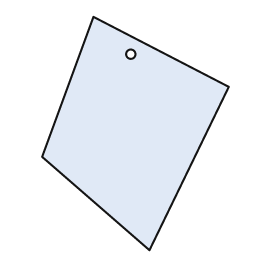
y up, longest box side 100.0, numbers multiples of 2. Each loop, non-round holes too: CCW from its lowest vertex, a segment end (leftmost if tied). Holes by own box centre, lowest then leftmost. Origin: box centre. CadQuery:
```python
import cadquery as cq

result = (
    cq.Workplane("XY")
    .moveTo(6.0, -50.0)
    .lineTo(40.0, 20.0)
    .lineTo(-18.0, 50.0)
    .lineTo(-40.0, -10.0)
    .close()
    .moveTo(-2.0, 34.0)
    .circle(2.0)
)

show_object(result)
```